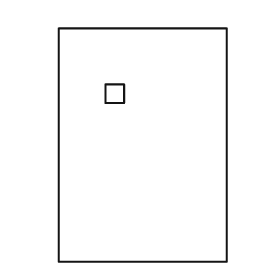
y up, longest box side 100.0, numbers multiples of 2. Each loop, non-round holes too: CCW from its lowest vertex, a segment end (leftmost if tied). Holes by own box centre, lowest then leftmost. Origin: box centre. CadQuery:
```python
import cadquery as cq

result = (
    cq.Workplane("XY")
    .moveTo(-36.0, -50.0)
    .lineTo(36.0, -50.0)
    .lineTo(36.0, 50.0)
    .lineTo(-36.0, 50.0)
    .close()
    .moveTo(-16.0, 18.0)
    .lineTo(-8.0, 18.0)
    .lineTo(-8.0, 26.0)
    .lineTo(-16.0, 26.0)
    .close()
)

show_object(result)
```